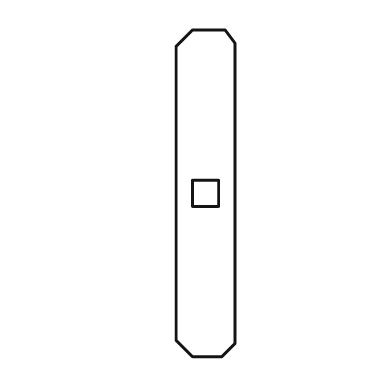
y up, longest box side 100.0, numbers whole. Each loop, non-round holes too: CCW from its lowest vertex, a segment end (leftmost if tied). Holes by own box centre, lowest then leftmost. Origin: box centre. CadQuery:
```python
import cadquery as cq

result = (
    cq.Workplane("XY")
    .moveTo(-4.0, -50.0)
    .lineTo(5.0, -50.0)
    .lineTo(9.0, -46.0)
    .lineTo(9.0, 46.0)
    .lineTo(6.0, 50.0)
    .lineTo(-4.0, 50.0)
    .lineTo(-9.0, 45.0)
    .lineTo(-9.0, -45.0)
    .close()
    .moveTo(-4.0, -4.0)
    .lineTo(4.0, -4.0)
    .lineTo(4.0, 4.0)
    .lineTo(-4.0, 4.0)
    .close()
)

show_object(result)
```